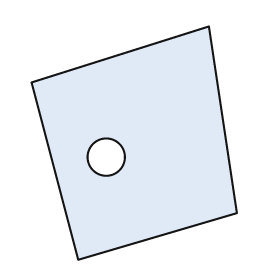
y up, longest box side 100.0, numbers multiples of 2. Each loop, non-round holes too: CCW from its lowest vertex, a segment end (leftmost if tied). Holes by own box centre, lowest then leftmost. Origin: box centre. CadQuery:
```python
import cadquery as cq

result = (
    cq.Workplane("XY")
    .moveTo(-24.0, -50.0)
    .lineTo(44.0, -30.0)
    .lineTo(32.0, 50.0)
    .lineTo(-44.0, 26.0)
    .close()
    .moveTo(-12.0, -6.0)
    .circle(8.0)
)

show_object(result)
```